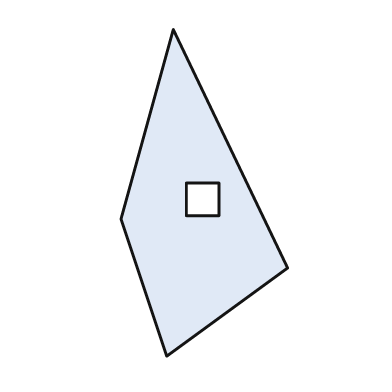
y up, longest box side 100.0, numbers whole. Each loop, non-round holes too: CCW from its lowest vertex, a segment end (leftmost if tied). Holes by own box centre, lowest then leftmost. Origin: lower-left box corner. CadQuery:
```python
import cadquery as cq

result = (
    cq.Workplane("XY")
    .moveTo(14.0, 0.0)
    .lineTo(51.0, 27.0)
    .lineTo(16.0, 100.0)
    .lineTo(0.0, 42.0)
    .close()
    .moveTo(20.0, 43.0)
    .lineTo(30.0, 43.0)
    .lineTo(30.0, 53.0)
    .lineTo(20.0, 53.0)
    .close()
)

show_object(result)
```